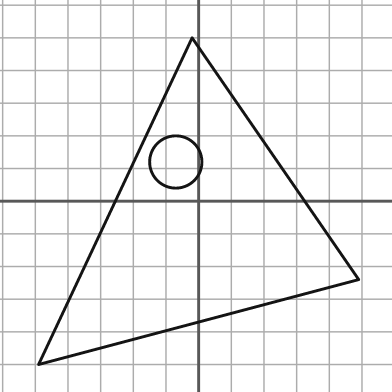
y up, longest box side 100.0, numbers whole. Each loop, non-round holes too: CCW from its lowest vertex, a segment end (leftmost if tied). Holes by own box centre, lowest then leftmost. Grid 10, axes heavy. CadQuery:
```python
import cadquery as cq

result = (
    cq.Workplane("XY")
    .moveTo(-49.0, -50.0)
    .lineTo(49.0, -24.0)
    .lineTo(-2.0, 50.0)
    .close()
    .moveTo(-7.0, 12.0)
    .circle(8.0)
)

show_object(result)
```